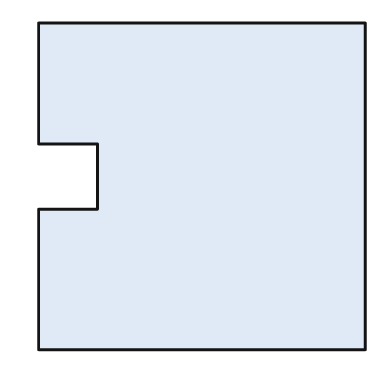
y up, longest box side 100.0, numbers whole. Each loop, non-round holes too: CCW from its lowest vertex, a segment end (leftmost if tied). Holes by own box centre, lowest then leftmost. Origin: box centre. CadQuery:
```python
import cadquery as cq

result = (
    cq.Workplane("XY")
    .moveTo(-50.0, -50.0)
    .lineTo(50.0, -50.0)
    .lineTo(50.0, 50.0)
    .lineTo(-50.0, 50.0)
    .lineTo(-50.0, 13.0)
    .lineTo(-32.0, 13.0)
    .lineTo(-32.0, -7.0)
    .lineTo(-50.0, -7.0)
    .close()
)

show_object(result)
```